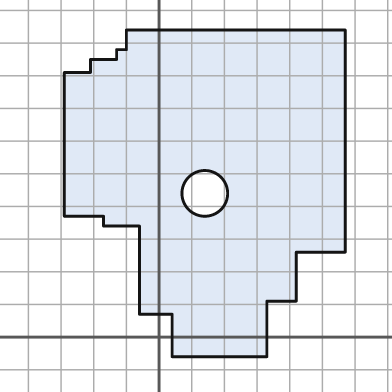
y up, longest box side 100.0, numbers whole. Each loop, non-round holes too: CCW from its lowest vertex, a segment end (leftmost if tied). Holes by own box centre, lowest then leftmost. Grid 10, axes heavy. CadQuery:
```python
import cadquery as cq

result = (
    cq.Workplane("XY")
    .moveTo(4.0, -6.0)
    .lineTo(33.0, -6.0)
    .lineTo(33.0, 11.0)
    .lineTo(42.0, 11.0)
    .lineTo(42.0, 26.0)
    .lineTo(57.0, 26.0)
    .lineTo(57.0, 94.0)
    .lineTo(-10.0, 94.0)
    .lineTo(-10.0, 88.0)
    .lineTo(-13.0, 88.0)
    .lineTo(-13.0, 85.0)
    .lineTo(-21.0, 85.0)
    .lineTo(-21.0, 81.0)
    .lineTo(-29.0, 81.0)
    .lineTo(-29.0, 37.0)
    .lineTo(-17.0, 37.0)
    .lineTo(-17.0, 34.0)
    .lineTo(-6.0, 34.0)
    .lineTo(-6.0, 7.0)
    .lineTo(4.0, 7.0)
    .close()
    .moveTo(14.0, 44.0)
    .circle(7.0)
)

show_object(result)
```